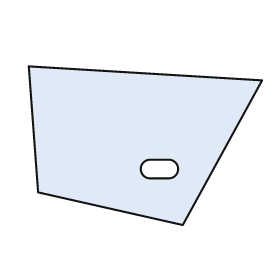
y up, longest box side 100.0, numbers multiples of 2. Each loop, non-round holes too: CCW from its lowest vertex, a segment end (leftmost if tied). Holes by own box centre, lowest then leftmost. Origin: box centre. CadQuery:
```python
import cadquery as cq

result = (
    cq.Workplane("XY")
    .moveTo(16.0, -34.0)
    .lineTo(50.0, 28.0)
    .lineTo(-50.0, 34.0)
    .lineTo(-46.0, -20.0)
    .close()
    .moveTo(2.0, -14.0)
    .lineTo(10.0, -14.0)
    .threePointArc((14.0, -10.0), (10.0, -6.0))
    .lineTo(2.0, -6.0)
    .threePointArc((-2.0, -10.0), (2.0, -14.0))
    .close()
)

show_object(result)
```